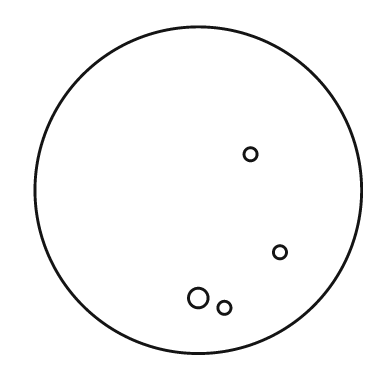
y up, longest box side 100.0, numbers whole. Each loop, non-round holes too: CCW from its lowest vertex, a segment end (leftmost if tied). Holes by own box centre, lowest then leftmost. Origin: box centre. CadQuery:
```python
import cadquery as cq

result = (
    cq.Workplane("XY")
    .moveTo(0.0, 0.0)
    .circle(50.0)
    .moveTo(8.0, -36.0)
    .circle(2.0)
    .moveTo(0.0, -33.0)
    .circle(3.0)
    .moveTo(25.0, -19.0)
    .circle(2.0)
    .moveTo(16.0, 11.0)
    .circle(2.0)
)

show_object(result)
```